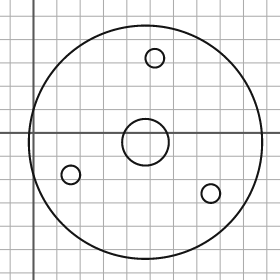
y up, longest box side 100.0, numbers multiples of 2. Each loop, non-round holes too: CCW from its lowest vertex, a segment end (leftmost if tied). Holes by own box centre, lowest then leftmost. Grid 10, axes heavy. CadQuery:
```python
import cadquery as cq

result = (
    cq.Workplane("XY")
    .moveTo(48.0, -4.0)
    .circle(50.0)
    .moveTo(76.0, -26.0)
    .circle(4.0)
    .moveTo(16.0, -18.0)
    .circle(4.0)
    .moveTo(48.0, -4.0)
    .circle(10.0)
    .moveTo(52.0, 32.0)
    .circle(4.0)
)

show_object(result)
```